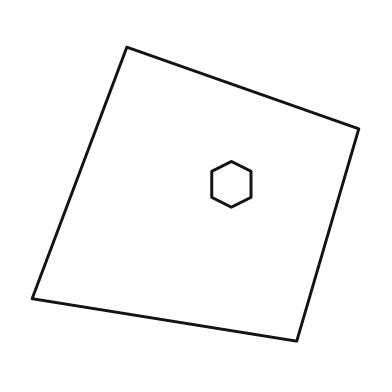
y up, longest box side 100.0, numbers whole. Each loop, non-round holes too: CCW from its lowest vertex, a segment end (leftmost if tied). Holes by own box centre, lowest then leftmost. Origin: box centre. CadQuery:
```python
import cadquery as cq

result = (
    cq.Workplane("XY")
    .moveTo(31.0, -45.0)
    .lineTo(50.0, 20.0)
    .lineTo(-21.0, 45.0)
    .lineTo(-50.0, -32.0)
    .close()
    .moveTo(11.0, -4.0)
    .lineTo(17.0, -1.0)
    .lineTo(17.0, 7.0)
    .lineTo(11.0, 10.0)
    .lineTo(5.0, 7.0)
    .lineTo(5.0, -1.0)
    .close()
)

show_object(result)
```